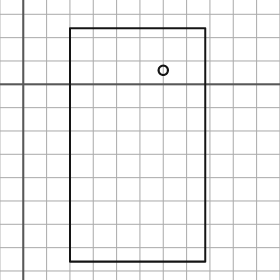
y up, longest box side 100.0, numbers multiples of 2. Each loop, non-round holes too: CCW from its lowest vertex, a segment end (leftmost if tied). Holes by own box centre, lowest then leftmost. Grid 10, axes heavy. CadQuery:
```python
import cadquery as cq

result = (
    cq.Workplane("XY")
    .moveTo(20.0, -76.0)
    .lineTo(78.0, -76.0)
    .lineTo(78.0, 24.0)
    .lineTo(20.0, 24.0)
    .close()
    .moveTo(60.0, 6.0)
    .circle(2.0)
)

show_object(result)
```